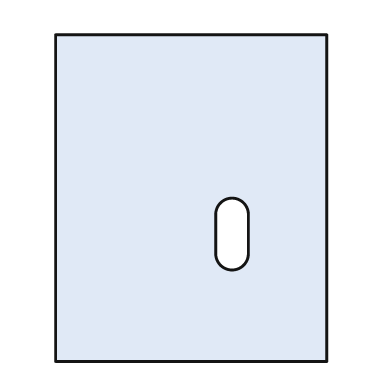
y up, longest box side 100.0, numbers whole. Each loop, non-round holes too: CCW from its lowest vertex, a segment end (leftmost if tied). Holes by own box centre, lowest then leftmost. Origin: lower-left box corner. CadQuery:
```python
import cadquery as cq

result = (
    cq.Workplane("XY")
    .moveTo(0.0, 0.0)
    .lineTo(83.0, 0.0)
    .lineTo(83.0, 100.0)
    .lineTo(0.0, 100.0)
    .close()
    .moveTo(49.0, 33.0)
    .threePointArc((54.0, 28.0), (59.0, 33.0))
    .lineTo(59.0, 45.0)
    .threePointArc((54.0, 50.0), (49.0, 45.0))
    .close()
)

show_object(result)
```